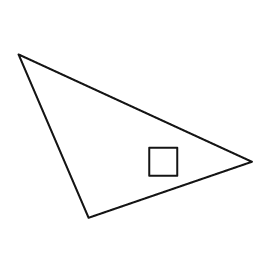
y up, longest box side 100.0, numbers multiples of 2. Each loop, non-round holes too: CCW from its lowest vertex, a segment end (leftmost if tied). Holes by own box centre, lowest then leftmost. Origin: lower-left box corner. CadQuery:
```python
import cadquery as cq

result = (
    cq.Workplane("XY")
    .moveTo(30.0, 0.0)
    .lineTo(100.0, 24.0)
    .lineTo(0.0, 70.0)
    .close()
    .moveTo(56.0, 18.0)
    .lineTo(68.0, 18.0)
    .lineTo(68.0, 30.0)
    .lineTo(56.0, 30.0)
    .close()
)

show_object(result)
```